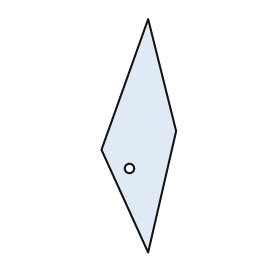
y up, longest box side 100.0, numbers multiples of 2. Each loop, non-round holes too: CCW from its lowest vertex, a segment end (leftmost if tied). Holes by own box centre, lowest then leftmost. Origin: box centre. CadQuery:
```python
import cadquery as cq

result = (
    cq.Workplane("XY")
    .moveTo(4.0, -50.0)
    .lineTo(16.0, 2.0)
    .lineTo(4.0, 50.0)
    .lineTo(-16.0, -6.0)
    .close()
    .moveTo(-4.0, -14.0)
    .circle(2.0)
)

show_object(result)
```